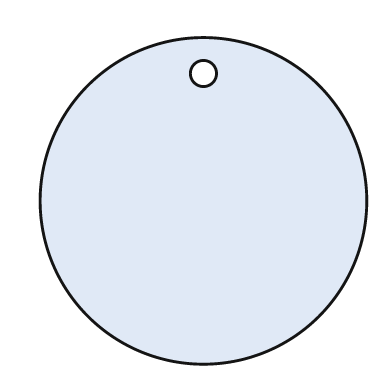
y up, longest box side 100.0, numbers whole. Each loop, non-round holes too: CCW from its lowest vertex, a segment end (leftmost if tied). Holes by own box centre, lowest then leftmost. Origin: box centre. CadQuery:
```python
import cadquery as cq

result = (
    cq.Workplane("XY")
    .moveTo(0.0, 0.0)
    .circle(50.0)
    .moveTo(0.0, 39.0)
    .circle(4.0)
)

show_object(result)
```